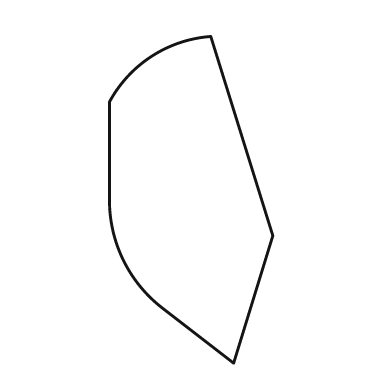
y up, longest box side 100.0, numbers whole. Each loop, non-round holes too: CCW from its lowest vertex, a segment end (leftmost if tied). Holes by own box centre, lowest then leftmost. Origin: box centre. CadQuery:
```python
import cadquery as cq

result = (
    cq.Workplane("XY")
    .moveTo(13.0, -50.0)
    .lineTo(25.0, -11.0)
    .lineTo(6.0, 50.0)
    .threePointArc((-12.0, 44.0), (-25.0, 30.0))
    .lineTo(-25.0, 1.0)
    .threePointArc((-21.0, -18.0), (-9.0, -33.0))
    .close()
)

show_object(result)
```